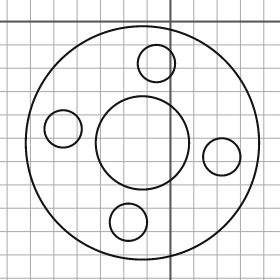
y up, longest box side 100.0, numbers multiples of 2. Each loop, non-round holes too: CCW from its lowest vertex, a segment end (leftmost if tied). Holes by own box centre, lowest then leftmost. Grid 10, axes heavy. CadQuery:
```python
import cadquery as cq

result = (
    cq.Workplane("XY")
    .moveTo(-12.0, -52.0)
    .circle(50.0)
    .moveTo(-18.0, -86.0)
    .circle(8.0)
    .moveTo(22.0, -58.0)
    .circle(8.0)
    .moveTo(-12.0, -52.0)
    .circle(20.0)
    .moveTo(-46.0, -46.0)
    .circle(8.0)
    .moveTo(-6.0, -18.0)
    .circle(8.0)
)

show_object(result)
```